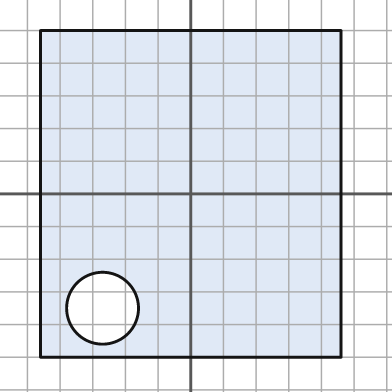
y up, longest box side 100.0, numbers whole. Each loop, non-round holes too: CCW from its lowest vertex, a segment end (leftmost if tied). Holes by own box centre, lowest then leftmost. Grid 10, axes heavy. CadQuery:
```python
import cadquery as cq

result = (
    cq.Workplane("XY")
    .moveTo(-46.0, -50.0)
    .lineTo(46.0, -50.0)
    .lineTo(46.0, 50.0)
    .lineTo(-46.0, 50.0)
    .close()
    .moveTo(-27.0, -35.0)
    .circle(11.0)
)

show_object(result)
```